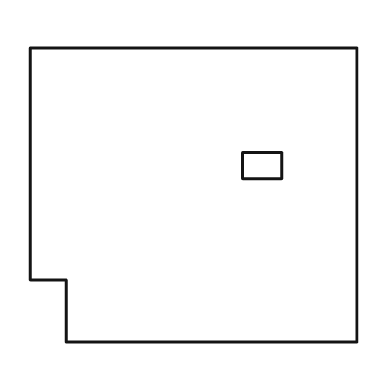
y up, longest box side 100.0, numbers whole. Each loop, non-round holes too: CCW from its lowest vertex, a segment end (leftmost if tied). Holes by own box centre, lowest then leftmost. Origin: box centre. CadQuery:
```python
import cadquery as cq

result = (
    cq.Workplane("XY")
    .moveTo(-39.0, -45.0)
    .lineTo(50.0, -45.0)
    .lineTo(50.0, 45.0)
    .lineTo(-50.0, 45.0)
    .lineTo(-50.0, -26.0)
    .lineTo(-39.0, -26.0)
    .close()
    .moveTo(15.0, 5.0)
    .lineTo(27.0, 5.0)
    .lineTo(27.0, 13.0)
    .lineTo(15.0, 13.0)
    .close()
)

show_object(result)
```